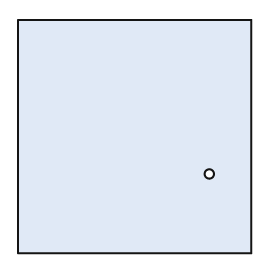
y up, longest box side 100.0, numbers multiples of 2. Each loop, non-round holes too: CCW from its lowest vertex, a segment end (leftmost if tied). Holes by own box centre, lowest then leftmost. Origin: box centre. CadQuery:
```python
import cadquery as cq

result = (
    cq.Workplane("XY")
    .moveTo(-50.0, -50.0)
    .lineTo(50.0, -50.0)
    .lineTo(50.0, 50.0)
    .lineTo(-50.0, 50.0)
    .close()
    .moveTo(32.0, -16.0)
    .circle(2.0)
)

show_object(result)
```